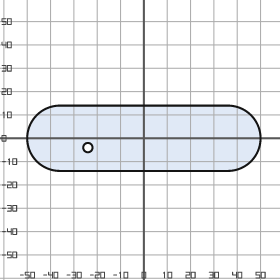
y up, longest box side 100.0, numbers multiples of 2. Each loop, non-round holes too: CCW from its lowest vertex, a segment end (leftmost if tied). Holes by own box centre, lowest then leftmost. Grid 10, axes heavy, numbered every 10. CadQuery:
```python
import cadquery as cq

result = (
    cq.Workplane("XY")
    .moveTo(-36.0, -14.0)
    .lineTo(36.0, -14.0)
    .threePointArc((50.0, 0.0), (36.0, 14.0))
    .lineTo(-36.0, 14.0)
    .threePointArc((-50.0, 0.0), (-36.0, -14.0))
    .close()
    .moveTo(-24.0, -4.0)
    .circle(2.0)
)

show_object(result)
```